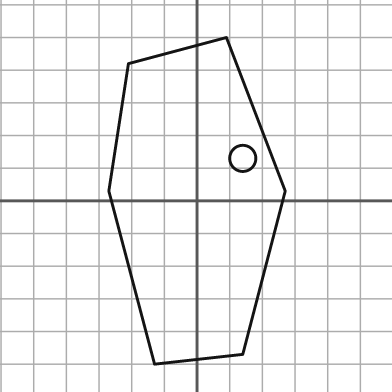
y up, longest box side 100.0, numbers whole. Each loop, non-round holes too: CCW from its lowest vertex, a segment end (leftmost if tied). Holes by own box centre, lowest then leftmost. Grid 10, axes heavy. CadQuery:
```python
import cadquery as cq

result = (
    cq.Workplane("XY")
    .moveTo(-13.0, -50.0)
    .lineTo(14.0, -47.0)
    .lineTo(27.0, 3.0)
    .lineTo(9.0, 50.0)
    .lineTo(-21.0, 42.0)
    .lineTo(-27.0, 3.0)
    .close()
    .moveTo(14.0, 13.0)
    .circle(4.0)
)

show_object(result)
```